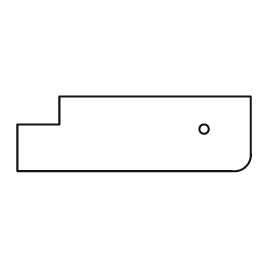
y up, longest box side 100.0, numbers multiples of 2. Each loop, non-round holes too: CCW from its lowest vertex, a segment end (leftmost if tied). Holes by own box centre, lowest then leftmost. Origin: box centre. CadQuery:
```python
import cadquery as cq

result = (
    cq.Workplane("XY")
    .moveTo(-50.0, -16.0)
    .lineTo(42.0, -16.0)
    .threePointArc((48.0, -14.0), (50.0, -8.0))
    .lineTo(50.0, 16.0)
    .lineTo(-32.0, 16.0)
    .lineTo(-32.0, 4.0)
    .lineTo(-50.0, 4.0)
    .close()
    .moveTo(30.0, 2.0)
    .circle(2.0)
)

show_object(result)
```